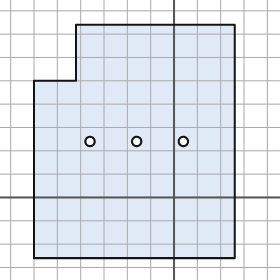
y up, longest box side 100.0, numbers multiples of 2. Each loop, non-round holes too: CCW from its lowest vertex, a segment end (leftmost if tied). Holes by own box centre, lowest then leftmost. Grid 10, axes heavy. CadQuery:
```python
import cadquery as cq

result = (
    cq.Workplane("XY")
    .moveTo(-60.0, -26.0)
    .lineTo(26.0, -26.0)
    .lineTo(26.0, 74.0)
    .lineTo(-42.0, 74.0)
    .lineTo(-42.0, 50.0)
    .lineTo(-60.0, 50.0)
    .close()
    .moveTo(-36.0, 24.0)
    .circle(2.0)
    .moveTo(-16.0, 24.0)
    .circle(2.0)
    .moveTo(4.0, 24.0)
    .circle(2.0)
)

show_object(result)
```